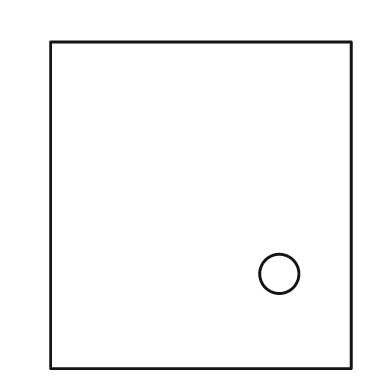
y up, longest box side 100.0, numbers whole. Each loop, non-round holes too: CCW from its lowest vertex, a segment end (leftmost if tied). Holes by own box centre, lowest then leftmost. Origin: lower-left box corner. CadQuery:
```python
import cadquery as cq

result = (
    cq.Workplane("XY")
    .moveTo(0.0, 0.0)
    .lineTo(92.0, 0.0)
    .lineTo(92.0, 100.0)
    .lineTo(0.0, 100.0)
    .close()
    .moveTo(70.0, 29.0)
    .circle(6.0)
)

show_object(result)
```